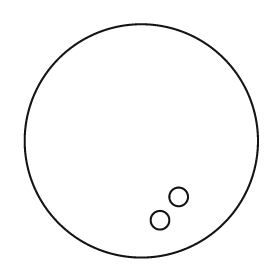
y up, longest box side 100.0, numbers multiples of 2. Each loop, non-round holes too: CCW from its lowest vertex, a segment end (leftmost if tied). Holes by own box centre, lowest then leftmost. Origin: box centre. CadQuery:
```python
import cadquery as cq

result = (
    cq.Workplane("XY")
    .moveTo(0.0, 0.0)
    .circle(50.0)
    .moveTo(8.0, -34.0)
    .circle(4.0)
    .moveTo(16.0, -24.0)
    .circle(4.0)
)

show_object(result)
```